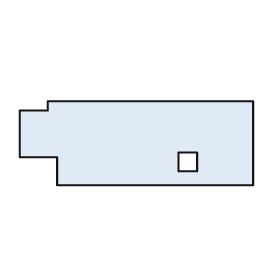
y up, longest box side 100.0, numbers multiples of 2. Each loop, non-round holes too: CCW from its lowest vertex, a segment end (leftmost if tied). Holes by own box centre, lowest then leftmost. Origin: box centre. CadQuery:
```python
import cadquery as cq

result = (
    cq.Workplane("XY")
    .moveTo(-34.0, -18.0)
    .lineTo(50.0, -18.0)
    .lineTo(50.0, 18.0)
    .lineTo(-38.0, 18.0)
    .lineTo(-38.0, 14.0)
    .lineTo(-50.0, 14.0)
    .lineTo(-50.0, -6.0)
    .lineTo(-34.0, -6.0)
    .close()
    .moveTo(18.0, -12.0)
    .lineTo(26.0, -12.0)
    .lineTo(26.0, -4.0)
    .lineTo(18.0, -4.0)
    .close()
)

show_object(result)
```